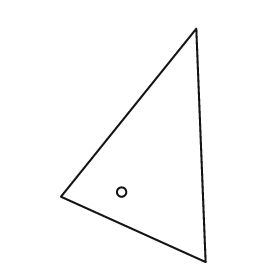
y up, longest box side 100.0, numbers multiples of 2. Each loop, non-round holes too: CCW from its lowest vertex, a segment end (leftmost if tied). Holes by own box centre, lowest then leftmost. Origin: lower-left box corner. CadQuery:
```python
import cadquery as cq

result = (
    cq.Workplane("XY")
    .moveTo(62.0, 0.0)
    .lineTo(58.0, 100.0)
    .lineTo(0.0, 28.0)
    .close()
    .moveTo(26.0, 30.0)
    .circle(2.0)
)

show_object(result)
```